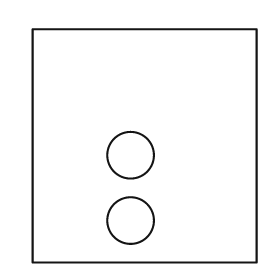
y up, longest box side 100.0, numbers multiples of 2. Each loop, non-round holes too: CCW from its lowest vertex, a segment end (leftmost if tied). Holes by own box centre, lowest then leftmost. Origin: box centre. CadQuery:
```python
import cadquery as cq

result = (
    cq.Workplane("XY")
    .moveTo(-48.0, -50.0)
    .lineTo(48.0, -50.0)
    .lineTo(48.0, 50.0)
    .lineTo(-48.0, 50.0)
    .close()
    .moveTo(-6.0, -32.0)
    .circle(10.0)
    .moveTo(-6.0, -4.0)
    .circle(10.0)
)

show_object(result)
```